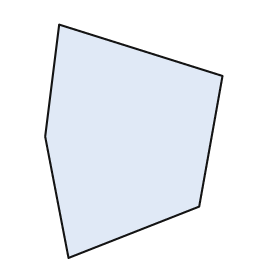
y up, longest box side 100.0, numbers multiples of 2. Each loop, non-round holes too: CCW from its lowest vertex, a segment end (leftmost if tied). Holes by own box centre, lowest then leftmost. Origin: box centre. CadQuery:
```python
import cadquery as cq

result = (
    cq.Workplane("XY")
    .moveTo(-28.0, -50.0)
    .lineTo(28.0, -28.0)
    .lineTo(38.0, 28.0)
    .lineTo(-32.0, 50.0)
    .lineTo(-38.0, 2.0)
    .close()
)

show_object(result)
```